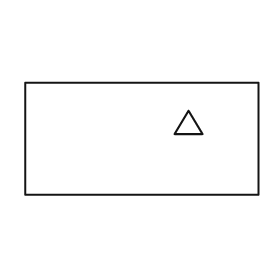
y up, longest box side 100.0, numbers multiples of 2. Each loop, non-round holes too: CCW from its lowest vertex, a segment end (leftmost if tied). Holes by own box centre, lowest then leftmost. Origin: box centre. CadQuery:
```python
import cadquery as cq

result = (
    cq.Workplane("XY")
    .moveTo(-50.0, -24.0)
    .lineTo(50.0, -24.0)
    .lineTo(50.0, 24.0)
    .lineTo(-50.0, 24.0)
    .close()
    .moveTo(14.0, 2.0)
    .lineTo(26.0, 2.0)
    .lineTo(20.0, 12.0)
    .close()
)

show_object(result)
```